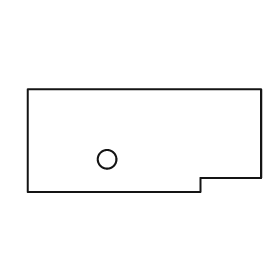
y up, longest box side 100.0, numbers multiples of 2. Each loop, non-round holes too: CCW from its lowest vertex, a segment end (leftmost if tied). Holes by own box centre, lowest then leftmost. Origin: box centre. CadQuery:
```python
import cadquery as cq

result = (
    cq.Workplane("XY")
    .moveTo(-50.0, -22.0)
    .lineTo(24.0, -22.0)
    .lineTo(24.0, -16.0)
    .lineTo(50.0, -16.0)
    .lineTo(50.0, 22.0)
    .lineTo(-50.0, 22.0)
    .close()
    .moveTo(-16.0, -8.0)
    .circle(4.0)
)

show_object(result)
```